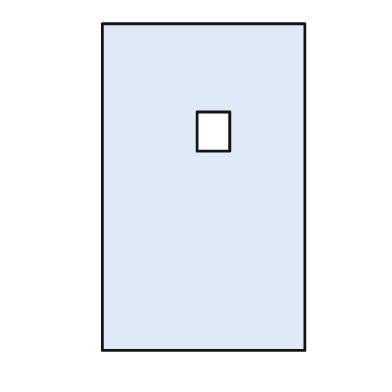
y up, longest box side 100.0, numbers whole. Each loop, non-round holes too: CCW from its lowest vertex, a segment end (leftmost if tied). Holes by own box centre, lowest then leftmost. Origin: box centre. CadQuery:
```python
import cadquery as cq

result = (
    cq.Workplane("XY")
    .moveTo(-31.0, -50.0)
    .lineTo(31.0, -50.0)
    .lineTo(31.0, 50.0)
    .lineTo(-31.0, 50.0)
    .close()
    .moveTo(-2.0, 11.0)
    .lineTo(8.0, 11.0)
    .lineTo(8.0, 23.0)
    .lineTo(-2.0, 23.0)
    .close()
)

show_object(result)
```